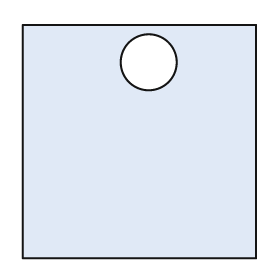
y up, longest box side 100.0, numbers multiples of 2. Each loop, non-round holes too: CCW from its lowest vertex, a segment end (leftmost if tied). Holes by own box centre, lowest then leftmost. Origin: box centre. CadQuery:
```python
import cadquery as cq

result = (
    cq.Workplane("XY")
    .moveTo(-50.0, -50.0)
    .lineTo(50.0, -50.0)
    .lineTo(50.0, 50.0)
    .lineTo(-50.0, 50.0)
    .close()
    .moveTo(4.0, 34.0)
    .circle(12.0)
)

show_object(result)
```